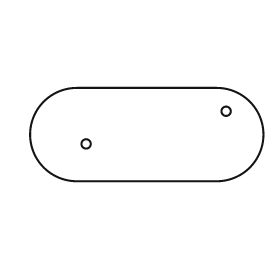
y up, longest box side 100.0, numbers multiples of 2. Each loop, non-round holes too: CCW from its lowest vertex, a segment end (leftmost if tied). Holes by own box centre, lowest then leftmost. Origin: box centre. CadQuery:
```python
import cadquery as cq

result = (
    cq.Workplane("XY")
    .moveTo(-30.0, -20.0)
    .lineTo(30.0, -20.0)
    .threePointArc((50.0, 0.0), (30.0, 20.0))
    .lineTo(-30.0, 20.0)
    .threePointArc((-50.0, 0.0), (-30.0, -20.0))
    .close()
    .moveTo(-26.0, -4.0)
    .circle(2.0)
    .moveTo(34.0, 10.0)
    .circle(2.0)
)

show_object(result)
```